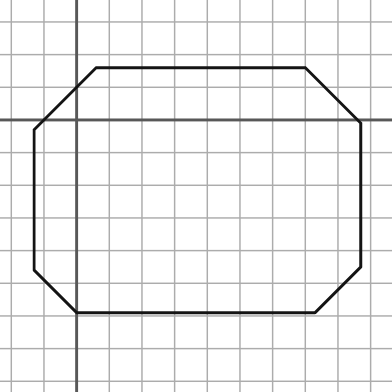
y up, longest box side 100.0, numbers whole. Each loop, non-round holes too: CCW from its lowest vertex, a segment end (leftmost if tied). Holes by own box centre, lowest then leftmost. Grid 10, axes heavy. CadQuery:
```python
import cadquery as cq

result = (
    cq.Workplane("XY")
    .moveTo(0.0, -59.0)
    .lineTo(73.0, -59.0)
    .lineTo(87.0, -45.0)
    .lineTo(87.0, -1.0)
    .lineTo(70.0, 16.0)
    .lineTo(6.0, 16.0)
    .lineTo(-13.0, -3.0)
    .lineTo(-13.0, -46.0)
    .close()
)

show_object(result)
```